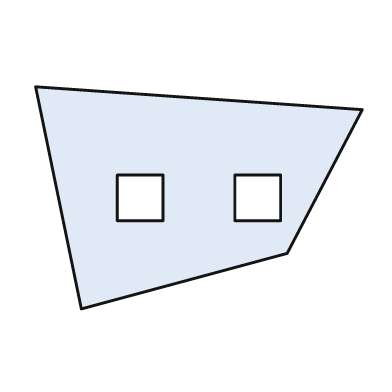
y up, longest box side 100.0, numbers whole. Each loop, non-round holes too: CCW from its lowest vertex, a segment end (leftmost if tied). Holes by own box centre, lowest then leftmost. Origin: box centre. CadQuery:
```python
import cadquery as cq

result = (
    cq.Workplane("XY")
    .moveTo(-36.0, -34.0)
    .lineTo(27.0, -17.0)
    .lineTo(50.0, 27.0)
    .lineTo(-50.0, 34.0)
    .close()
    .moveTo(-25.0, -7.0)
    .lineTo(-11.0, -7.0)
    .lineTo(-11.0, 7.0)
    .lineTo(-25.0, 7.0)
    .close()
    .moveTo(11.0, -7.0)
    .lineTo(25.0, -7.0)
    .lineTo(25.0, 7.0)
    .lineTo(11.0, 7.0)
    .close()
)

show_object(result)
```